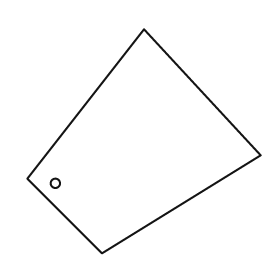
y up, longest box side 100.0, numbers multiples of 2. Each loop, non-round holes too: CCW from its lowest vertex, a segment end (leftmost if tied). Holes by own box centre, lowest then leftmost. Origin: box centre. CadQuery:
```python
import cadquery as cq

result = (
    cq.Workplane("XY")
    .moveTo(-18.0, -48.0)
    .lineTo(50.0, -6.0)
    .lineTo(0.0, 48.0)
    .lineTo(-50.0, -16.0)
    .close()
    .moveTo(-38.0, -18.0)
    .circle(2.0)
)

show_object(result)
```